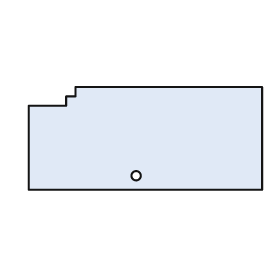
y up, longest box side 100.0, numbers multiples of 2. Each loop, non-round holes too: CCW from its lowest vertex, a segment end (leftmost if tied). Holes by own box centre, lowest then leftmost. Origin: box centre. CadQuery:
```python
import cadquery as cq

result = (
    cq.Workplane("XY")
    .moveTo(-50.0, -22.0)
    .lineTo(50.0, -22.0)
    .lineTo(50.0, 22.0)
    .lineTo(-30.0, 22.0)
    .lineTo(-30.0, 18.0)
    .lineTo(-34.0, 18.0)
    .lineTo(-34.0, 14.0)
    .lineTo(-50.0, 14.0)
    .close()
    .moveTo(-4.0, -16.0)
    .circle(2.0)
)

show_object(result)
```